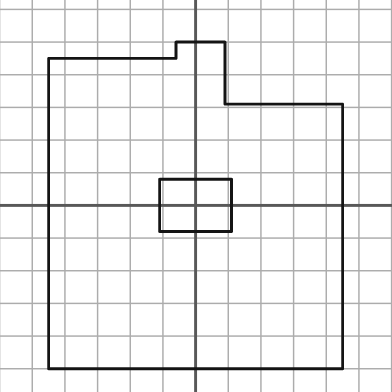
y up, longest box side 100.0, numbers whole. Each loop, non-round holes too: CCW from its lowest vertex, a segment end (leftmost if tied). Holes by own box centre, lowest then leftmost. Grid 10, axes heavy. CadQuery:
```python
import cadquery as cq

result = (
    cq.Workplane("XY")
    .moveTo(-45.0, -50.0)
    .lineTo(45.0, -50.0)
    .lineTo(45.0, 31.0)
    .lineTo(9.0, 31.0)
    .lineTo(9.0, 50.0)
    .lineTo(-6.0, 50.0)
    .lineTo(-6.0, 45.0)
    .lineTo(-45.0, 45.0)
    .close()
    .moveTo(-11.0, -8.0)
    .lineTo(11.0, -8.0)
    .lineTo(11.0, 8.0)
    .lineTo(-11.0, 8.0)
    .close()
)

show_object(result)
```